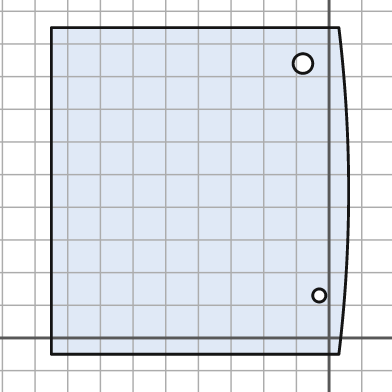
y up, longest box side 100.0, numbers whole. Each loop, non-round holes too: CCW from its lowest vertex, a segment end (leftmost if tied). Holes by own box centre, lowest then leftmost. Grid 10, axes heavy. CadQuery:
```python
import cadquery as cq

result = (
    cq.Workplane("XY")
    .moveTo(-85.0, -5.0)
    .lineTo(3.0, -5.0)
    .threePointArc((6.0, 45.0), (3.0, 95.0))
    .lineTo(-85.0, 95.0)
    .close()
    .moveTo(-3.0, 13.0)
    .circle(2.0)
    .moveTo(-8.0, 84.0)
    .circle(3.0)
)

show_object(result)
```